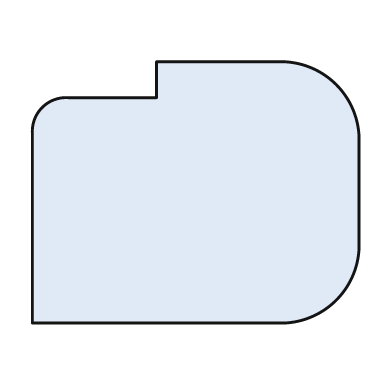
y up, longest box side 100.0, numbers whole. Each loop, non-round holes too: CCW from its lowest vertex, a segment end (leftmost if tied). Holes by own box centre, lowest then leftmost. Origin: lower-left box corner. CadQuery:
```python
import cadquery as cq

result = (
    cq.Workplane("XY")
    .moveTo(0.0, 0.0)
    .lineTo(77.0, 0.0)
    .threePointArc((93.0, 7.0), (100.0, 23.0))
    .lineTo(100.0, 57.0)
    .threePointArc((93.0, 73.0), (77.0, 80.0))
    .lineTo(38.0, 80.0)
    .lineTo(38.0, 69.0)
    .lineTo(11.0, 69.0)
    .threePointArc((3.0, 66.0), (0.0, 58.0))
    .close()
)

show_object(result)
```